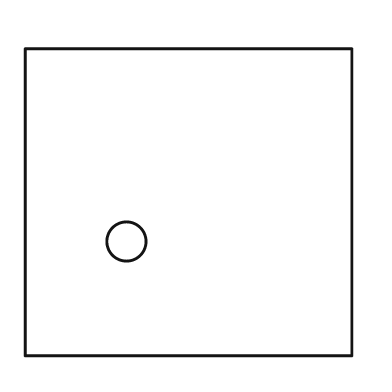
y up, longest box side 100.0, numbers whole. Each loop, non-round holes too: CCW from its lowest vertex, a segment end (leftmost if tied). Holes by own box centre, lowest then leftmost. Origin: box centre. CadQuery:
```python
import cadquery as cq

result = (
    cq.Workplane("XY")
    .moveTo(-50.0, -47.0)
    .lineTo(50.0, -47.0)
    .lineTo(50.0, 47.0)
    .lineTo(-50.0, 47.0)
    .close()
    .moveTo(-19.0, -12.0)
    .circle(6.0)
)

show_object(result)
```